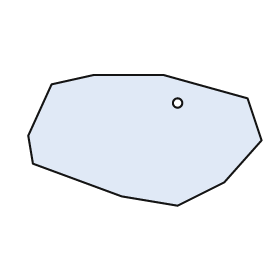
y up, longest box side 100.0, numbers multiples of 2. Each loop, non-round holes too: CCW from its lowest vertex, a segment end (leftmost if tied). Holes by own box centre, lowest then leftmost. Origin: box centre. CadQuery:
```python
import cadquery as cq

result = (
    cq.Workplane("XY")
    .moveTo(14.0, -28.0)
    .lineTo(34.0, -18.0)
    .lineTo(50.0, 0.0)
    .lineTo(44.0, 18.0)
    .lineTo(8.0, 28.0)
    .lineTo(-22.0, 28.0)
    .lineTo(-40.0, 24.0)
    .lineTo(-50.0, 2.0)
    .lineTo(-48.0, -10.0)
    .lineTo(-10.0, -24.0)
    .close()
    .moveTo(14.0, 16.0)
    .circle(2.0)
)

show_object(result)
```